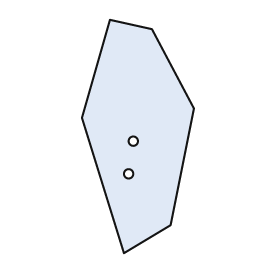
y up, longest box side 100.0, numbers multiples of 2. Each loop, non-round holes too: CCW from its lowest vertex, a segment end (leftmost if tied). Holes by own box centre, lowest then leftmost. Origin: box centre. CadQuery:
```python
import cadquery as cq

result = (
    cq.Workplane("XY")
    .moveTo(-6.0, -50.0)
    .lineTo(14.0, -38.0)
    .lineTo(24.0, 12.0)
    .lineTo(6.0, 46.0)
    .lineTo(-12.0, 50.0)
    .lineTo(-24.0, 8.0)
    .close()
    .moveTo(-4.0, -16.0)
    .circle(2.0)
    .moveTo(-2.0, -2.0)
    .circle(2.0)
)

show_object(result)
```